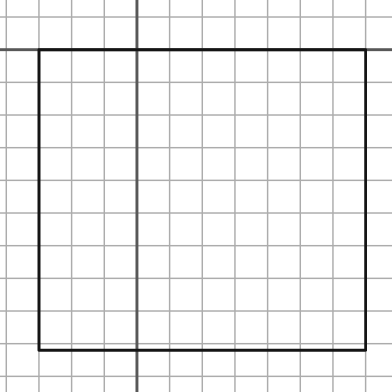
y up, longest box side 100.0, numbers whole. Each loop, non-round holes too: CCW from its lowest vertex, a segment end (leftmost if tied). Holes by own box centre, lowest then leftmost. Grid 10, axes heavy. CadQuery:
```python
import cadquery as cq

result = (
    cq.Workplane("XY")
    .moveTo(-30.0, -92.0)
    .lineTo(70.0, -92.0)
    .lineTo(70.0, 0.0)
    .lineTo(-30.0, 0.0)
    .close()
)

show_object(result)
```